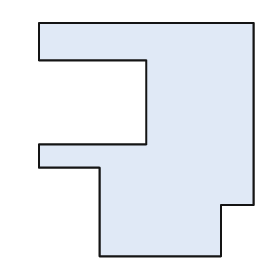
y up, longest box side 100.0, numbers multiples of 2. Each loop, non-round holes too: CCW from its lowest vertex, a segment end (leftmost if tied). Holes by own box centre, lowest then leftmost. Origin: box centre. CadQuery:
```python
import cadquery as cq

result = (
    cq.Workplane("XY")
    .moveTo(-20.0, -50.0)
    .lineTo(32.0, -50.0)
    .lineTo(32.0, -28.0)
    .lineTo(46.0, -28.0)
    .lineTo(46.0, 50.0)
    .lineTo(-46.0, 50.0)
    .lineTo(-46.0, 34.0)
    .lineTo(0.0, 34.0)
    .lineTo(0.0, -2.0)
    .lineTo(-46.0, -2.0)
    .lineTo(-46.0, -12.0)
    .lineTo(-20.0, -12.0)
    .close()
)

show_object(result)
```